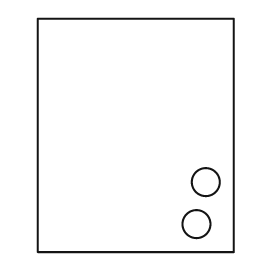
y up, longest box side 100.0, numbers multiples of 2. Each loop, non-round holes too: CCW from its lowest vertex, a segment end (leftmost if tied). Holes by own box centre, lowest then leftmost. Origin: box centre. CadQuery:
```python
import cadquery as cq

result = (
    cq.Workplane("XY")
    .moveTo(-42.0, -50.0)
    .lineTo(42.0, -50.0)
    .lineTo(42.0, 50.0)
    .lineTo(-42.0, 50.0)
    .close()
    .moveTo(26.0, -38.0)
    .circle(6.0)
    .moveTo(30.0, -20.0)
    .circle(6.0)
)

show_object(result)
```